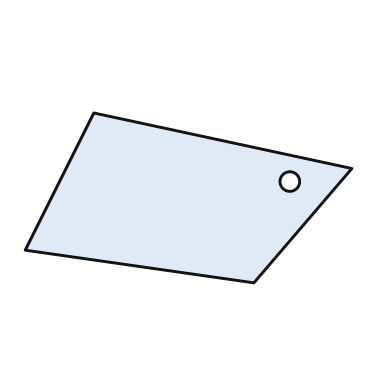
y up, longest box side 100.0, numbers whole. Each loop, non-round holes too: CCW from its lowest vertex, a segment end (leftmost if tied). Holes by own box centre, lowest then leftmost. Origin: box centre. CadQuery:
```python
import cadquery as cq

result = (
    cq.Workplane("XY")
    .moveTo(20.0, -26.0)
    .lineTo(50.0, 9.0)
    .lineTo(-29.0, 26.0)
    .lineTo(-50.0, -16.0)
    .close()
    .moveTo(31.0, 5.0)
    .circle(3.0)
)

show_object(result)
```